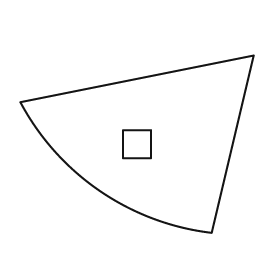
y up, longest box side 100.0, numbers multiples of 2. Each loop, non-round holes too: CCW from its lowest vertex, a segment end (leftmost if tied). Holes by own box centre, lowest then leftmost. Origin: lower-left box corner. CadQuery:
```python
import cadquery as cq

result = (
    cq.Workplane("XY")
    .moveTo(82.0, 0.0)
    .lineTo(100.0, 76.0)
    .lineTo(0.0, 56.0)
    .threePointArc((34.0, 18.0), (82.0, 0.0))
    .close()
    .moveTo(44.0, 32.0)
    .lineTo(56.0, 32.0)
    .lineTo(56.0, 44.0)
    .lineTo(44.0, 44.0)
    .close()
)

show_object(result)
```